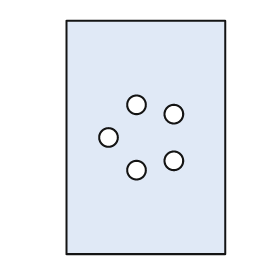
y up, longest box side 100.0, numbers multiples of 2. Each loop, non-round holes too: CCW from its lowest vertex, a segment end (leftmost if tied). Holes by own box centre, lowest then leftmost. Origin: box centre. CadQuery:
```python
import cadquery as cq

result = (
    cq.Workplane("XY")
    .moveTo(-34.0, -50.0)
    .lineTo(34.0, -50.0)
    .lineTo(34.0, 50.0)
    .lineTo(-34.0, 50.0)
    .close()
    .moveTo(-4.0, -14.0)
    .circle(4.0)
    .moveTo(12.0, -10.0)
    .circle(4.0)
    .moveTo(-16.0, 0.0)
    .circle(4.0)
    .moveTo(12.0, 10.0)
    .circle(4.0)
    .moveTo(-4.0, 14.0)
    .circle(4.0)
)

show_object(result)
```